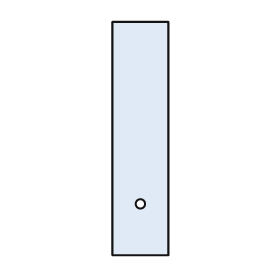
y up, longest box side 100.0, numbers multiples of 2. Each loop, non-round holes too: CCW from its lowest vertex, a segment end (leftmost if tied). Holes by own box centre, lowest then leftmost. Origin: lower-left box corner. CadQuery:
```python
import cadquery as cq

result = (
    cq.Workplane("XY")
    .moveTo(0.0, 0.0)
    .lineTo(24.0, 0.0)
    .lineTo(24.0, 100.0)
    .lineTo(0.0, 100.0)
    .close()
    .moveTo(12.0, 22.0)
    .circle(2.0)
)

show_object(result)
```